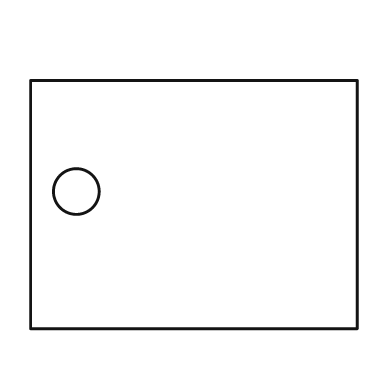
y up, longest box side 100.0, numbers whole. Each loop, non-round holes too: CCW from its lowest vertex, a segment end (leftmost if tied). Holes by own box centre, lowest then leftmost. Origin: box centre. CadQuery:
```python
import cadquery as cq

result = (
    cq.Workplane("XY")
    .moveTo(-50.0, -38.0)
    .lineTo(50.0, -38.0)
    .lineTo(50.0, 38.0)
    .lineTo(-50.0, 38.0)
    .close()
    .moveTo(-36.0, 4.0)
    .circle(7.0)
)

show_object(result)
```